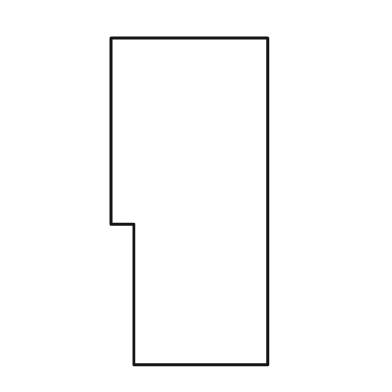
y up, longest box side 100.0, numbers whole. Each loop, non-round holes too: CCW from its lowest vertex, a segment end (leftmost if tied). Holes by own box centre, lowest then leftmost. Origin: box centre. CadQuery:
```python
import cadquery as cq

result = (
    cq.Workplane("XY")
    .moveTo(-17.0, -50.0)
    .lineTo(24.0, -50.0)
    .lineTo(24.0, 50.0)
    .lineTo(-24.0, 50.0)
    .lineTo(-24.0, -7.0)
    .lineTo(-17.0, -7.0)
    .close()
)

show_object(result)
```